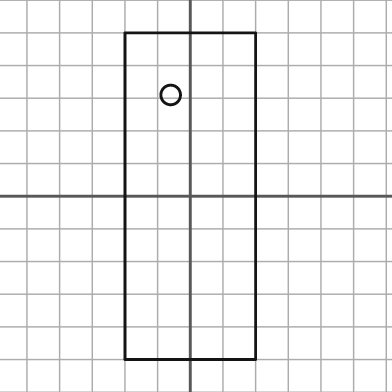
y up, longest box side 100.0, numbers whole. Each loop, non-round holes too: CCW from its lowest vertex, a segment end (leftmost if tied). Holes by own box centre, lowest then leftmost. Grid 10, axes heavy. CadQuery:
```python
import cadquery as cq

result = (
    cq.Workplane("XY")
    .moveTo(-20.0, -50.0)
    .lineTo(20.0, -50.0)
    .lineTo(20.0, 50.0)
    .lineTo(-20.0, 50.0)
    .close()
    .moveTo(-6.0, 31.0)
    .circle(3.0)
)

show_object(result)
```